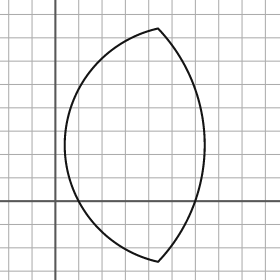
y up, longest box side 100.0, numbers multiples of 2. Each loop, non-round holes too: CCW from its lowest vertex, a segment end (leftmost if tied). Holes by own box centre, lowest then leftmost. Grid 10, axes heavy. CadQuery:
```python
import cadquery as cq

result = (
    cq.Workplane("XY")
    .moveTo(44.0, -26.0)
    .threePointArc((64.0, 24.0), (44.0, 74.0))
    .threePointArc((4.0, 24.0), (44.0, -26.0))
    .close()
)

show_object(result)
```